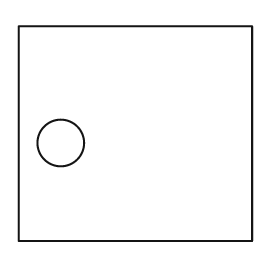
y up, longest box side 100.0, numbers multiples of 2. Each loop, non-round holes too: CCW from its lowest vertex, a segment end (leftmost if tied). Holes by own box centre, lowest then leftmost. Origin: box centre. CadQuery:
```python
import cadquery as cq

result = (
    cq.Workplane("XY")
    .moveTo(-50.0, -46.0)
    .lineTo(50.0, -46.0)
    .lineTo(50.0, 46.0)
    .lineTo(-50.0, 46.0)
    .close()
    .moveTo(-32.0, -4.0)
    .circle(10.0)
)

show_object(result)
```